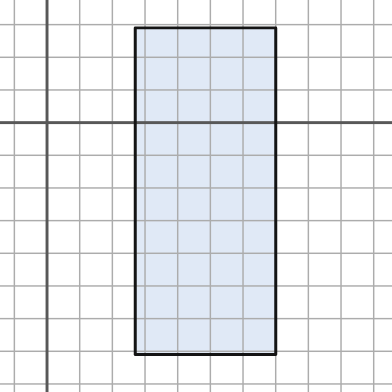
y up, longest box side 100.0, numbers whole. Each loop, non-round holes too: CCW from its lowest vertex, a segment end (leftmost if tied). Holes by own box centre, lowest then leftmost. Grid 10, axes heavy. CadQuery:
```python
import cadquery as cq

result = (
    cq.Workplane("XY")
    .moveTo(27.0, -71.0)
    .lineTo(70.0, -71.0)
    .lineTo(70.0, 29.0)
    .lineTo(27.0, 29.0)
    .close()
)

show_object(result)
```